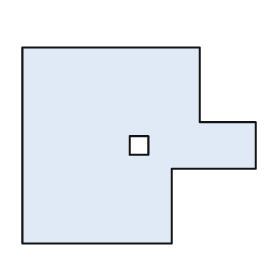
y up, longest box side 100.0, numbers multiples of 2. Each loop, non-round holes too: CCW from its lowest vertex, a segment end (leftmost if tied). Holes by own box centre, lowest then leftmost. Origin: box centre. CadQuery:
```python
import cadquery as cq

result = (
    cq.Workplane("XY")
    .moveTo(-50.0, -42.0)
    .lineTo(14.0, -42.0)
    .lineTo(14.0, -10.0)
    .lineTo(50.0, -10.0)
    .lineTo(50.0, 10.0)
    .lineTo(26.0, 10.0)
    .lineTo(26.0, 42.0)
    .lineTo(-50.0, 42.0)
    .close()
    .moveTo(-4.0, -4.0)
    .lineTo(4.0, -4.0)
    .lineTo(4.0, 4.0)
    .lineTo(-4.0, 4.0)
    .close()
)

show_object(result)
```